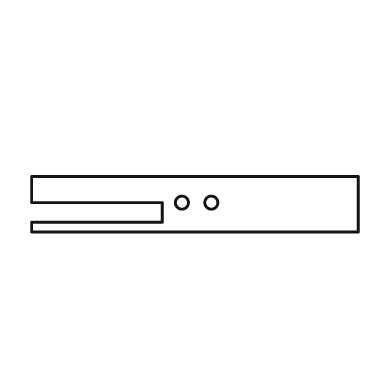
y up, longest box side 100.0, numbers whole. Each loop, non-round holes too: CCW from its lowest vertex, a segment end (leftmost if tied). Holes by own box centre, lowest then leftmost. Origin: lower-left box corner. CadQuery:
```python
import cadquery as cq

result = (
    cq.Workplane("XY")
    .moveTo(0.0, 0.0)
    .lineTo(100.0, 0.0)
    .lineTo(100.0, 17.0)
    .lineTo(0.0, 17.0)
    .lineTo(0.0, 9.0)
    .lineTo(40.0, 9.0)
    .lineTo(40.0, 3.0)
    .lineTo(0.0, 3.0)
    .close()
    .moveTo(46.0, 9.0)
    .circle(2.0)
    .moveTo(55.0, 9.0)
    .circle(2.0)
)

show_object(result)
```